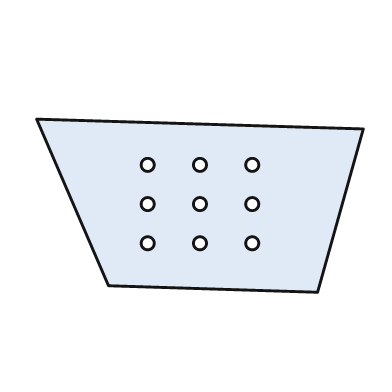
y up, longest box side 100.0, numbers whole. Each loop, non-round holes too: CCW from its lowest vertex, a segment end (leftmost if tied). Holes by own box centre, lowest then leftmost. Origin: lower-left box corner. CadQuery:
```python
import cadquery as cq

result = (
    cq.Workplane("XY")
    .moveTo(86.0, 0.0)
    .lineTo(100.0, 50.0)
    .lineTo(0.0, 53.0)
    .lineTo(22.0, 2.0)
    .close()
    .moveTo(34.0, 15.0)
    .circle(2.0)
    .moveTo(50.0, 15.0)
    .circle(2.0)
    .moveTo(66.0, 15.0)
    .circle(2.0)
    .moveTo(34.0, 27.0)
    .circle(2.0)
    .moveTo(50.0, 27.0)
    .circle(2.0)
    .moveTo(66.0, 27.0)
    .circle(2.0)
    .moveTo(34.0, 39.0)
    .circle(2.0)
    .moveTo(50.0, 39.0)
    .circle(2.0)
    .moveTo(66.0, 39.0)
    .circle(2.0)
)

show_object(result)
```